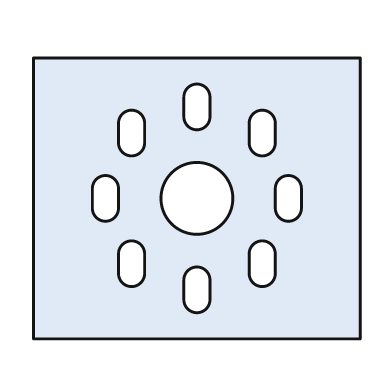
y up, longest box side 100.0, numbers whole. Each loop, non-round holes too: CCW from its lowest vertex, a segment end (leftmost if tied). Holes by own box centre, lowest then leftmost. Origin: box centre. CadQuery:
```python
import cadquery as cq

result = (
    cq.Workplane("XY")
    .moveTo(-50.0, -43.0)
    .lineTo(50.0, -43.0)
    .lineTo(50.0, 43.0)
    .lineTo(-50.0, 43.0)
    .close()
    .moveTo(-4.0, -31.0)
    .threePointArc((0.0, -35.0), (4.0, -31.0))
    .lineTo(4.0, -25.0)
    .threePointArc((0.0, -21.0), (-4.0, -25.0))
    .close()
    .moveTo(-24.0, -23.0)
    .threePointArc((-20.0, -27.0), (-16.0, -23.0))
    .lineTo(-16.0, -17.0)
    .threePointArc((-20.0, -13.0), (-24.0, -17.0))
    .close()
    .moveTo(16.0, -23.0)
    .threePointArc((20.0, -27.0), (24.0, -23.0))
    .lineTo(24.0, -17.0)
    .threePointArc((20.0, -13.0), (16.0, -17.0))
    .close()
    .moveTo(-32.0, -3.0)
    .threePointArc((-28.0, -7.0), (-24.0, -3.0))
    .lineTo(-24.0, 3.0)
    .threePointArc((-28.0, 7.0), (-32.0, 3.0))
    .close()
    .moveTo(0.0, 0.0)
    .circle(11.0)
    .moveTo(24.0, -3.0)
    .threePointArc((28.0, -7.0), (32.0, -3.0))
    .lineTo(32.0, 3.0)
    .threePointArc((28.0, 7.0), (24.0, 3.0))
    .close()
    .moveTo(-24.0, 17.0)
    .threePointArc((-20.0, 13.0), (-16.0, 17.0))
    .lineTo(-16.0, 23.0)
    .threePointArc((-20.0, 27.0), (-24.0, 23.0))
    .close()
    .moveTo(16.0, 17.0)
    .threePointArc((20.0, 13.0), (24.0, 17.0))
    .lineTo(24.0, 23.0)
    .threePointArc((20.0, 27.0), (16.0, 23.0))
    .close()
    .moveTo(-4.0, 25.0)
    .threePointArc((0.0, 21.0), (4.0, 25.0))
    .lineTo(4.0, 31.0)
    .threePointArc((0.0, 35.0), (-4.0, 31.0))
    .close()
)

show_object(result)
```